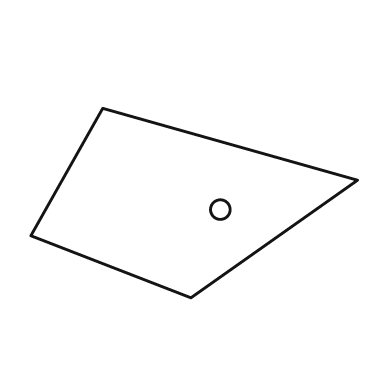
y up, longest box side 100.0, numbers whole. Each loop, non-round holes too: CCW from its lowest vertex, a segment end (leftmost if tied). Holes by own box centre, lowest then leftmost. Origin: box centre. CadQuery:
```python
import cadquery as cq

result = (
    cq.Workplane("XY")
    .moveTo(-1.0, -29.0)
    .lineTo(50.0, 7.0)
    .lineTo(-28.0, 29.0)
    .lineTo(-50.0, -10.0)
    .close()
    .moveTo(8.0, -2.0)
    .circle(3.0)
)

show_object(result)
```